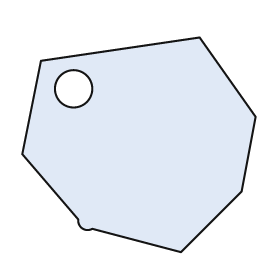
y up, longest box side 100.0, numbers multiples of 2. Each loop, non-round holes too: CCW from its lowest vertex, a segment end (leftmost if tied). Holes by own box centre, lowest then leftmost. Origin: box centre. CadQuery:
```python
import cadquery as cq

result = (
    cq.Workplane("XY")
    .moveTo(18.0, -46.0)
    .lineTo(44.0, -20.0)
    .lineTo(50.0, 12.0)
    .lineTo(26.0, 46.0)
    .lineTo(-42.0, 36.0)
    .lineTo(-50.0, -4.0)
    .lineTo(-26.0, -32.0)
    .threePointArc((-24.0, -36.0), (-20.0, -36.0))
    .close()
    .moveTo(-28.0, 24.0)
    .circle(8.0)
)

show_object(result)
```